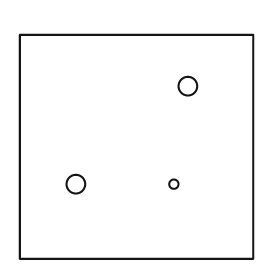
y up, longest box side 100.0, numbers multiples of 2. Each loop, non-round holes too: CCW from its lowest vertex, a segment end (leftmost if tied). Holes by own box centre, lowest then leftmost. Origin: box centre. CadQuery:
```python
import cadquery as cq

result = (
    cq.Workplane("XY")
    .moveTo(-50.0, -48.0)
    .lineTo(50.0, -48.0)
    .lineTo(50.0, 48.0)
    .lineTo(-50.0, 48.0)
    .close()
    .moveTo(-26.0, -16.0)
    .circle(4.0)
    .moveTo(16.0, -16.0)
    .circle(2.0)
    .moveTo(22.0, 26.0)
    .circle(4.0)
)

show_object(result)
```